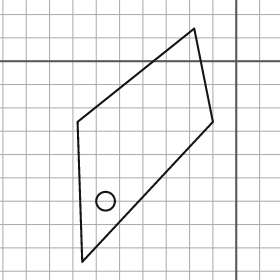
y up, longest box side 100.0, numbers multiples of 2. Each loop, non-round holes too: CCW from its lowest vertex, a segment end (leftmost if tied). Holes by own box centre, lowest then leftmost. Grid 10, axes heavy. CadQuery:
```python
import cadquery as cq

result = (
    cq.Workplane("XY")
    .moveTo(-66.0, -86.0)
    .lineTo(-10.0, -26.0)
    .lineTo(-18.0, 14.0)
    .lineTo(-68.0, -26.0)
    .close()
    .moveTo(-56.0, -60.0)
    .circle(4.0)
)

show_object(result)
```